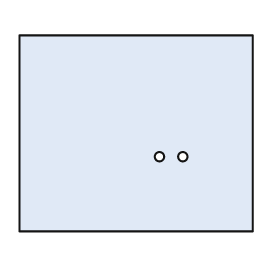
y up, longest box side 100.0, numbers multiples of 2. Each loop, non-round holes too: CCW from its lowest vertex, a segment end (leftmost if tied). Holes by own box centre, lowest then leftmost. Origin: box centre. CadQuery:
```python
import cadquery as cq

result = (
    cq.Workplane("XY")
    .moveTo(-50.0, -42.0)
    .lineTo(50.0, -42.0)
    .lineTo(50.0, 42.0)
    .lineTo(-50.0, 42.0)
    .close()
    .moveTo(10.0, -10.0)
    .circle(2.0)
    .moveTo(20.0, -10.0)
    .circle(2.0)
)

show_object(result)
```